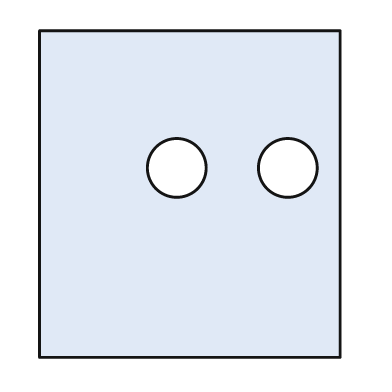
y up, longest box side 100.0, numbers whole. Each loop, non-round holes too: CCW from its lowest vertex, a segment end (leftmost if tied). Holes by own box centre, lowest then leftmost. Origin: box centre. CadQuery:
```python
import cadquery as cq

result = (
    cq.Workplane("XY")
    .moveTo(-46.0, -50.0)
    .lineTo(46.0, -50.0)
    .lineTo(46.0, 50.0)
    .lineTo(-46.0, 50.0)
    .close()
    .moveTo(-4.0, 8.0)
    .circle(9.0)
    .moveTo(30.0, 8.0)
    .circle(9.0)
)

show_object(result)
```